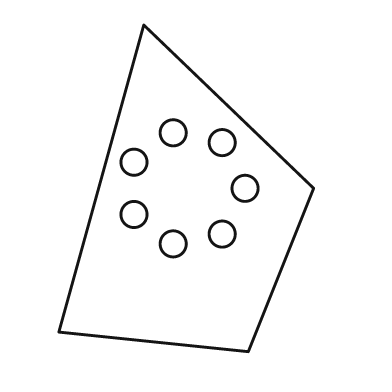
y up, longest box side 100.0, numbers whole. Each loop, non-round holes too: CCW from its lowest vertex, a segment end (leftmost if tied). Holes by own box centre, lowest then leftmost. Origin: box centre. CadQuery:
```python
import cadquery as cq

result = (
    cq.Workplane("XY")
    .moveTo(19.0, -50.0)
    .lineTo(39.0, 0.0)
    .lineTo(-13.0, 50.0)
    .lineTo(-39.0, -44.0)
    .close()
    .moveTo(-4.0, -17.0)
    .circle(4.0)
    .moveTo(11.0, -14.0)
    .circle(4.0)
    .moveTo(-16.0, -8.0)
    .circle(4.0)
    .moveTo(18.0, 0.0)
    .circle(4.0)
    .moveTo(-16.0, 8.0)
    .circle(4.0)
    .moveTo(11.0, 14.0)
    .circle(4.0)
    .moveTo(-4.0, 17.0)
    .circle(4.0)
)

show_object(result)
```